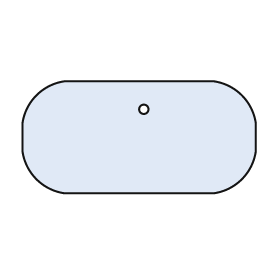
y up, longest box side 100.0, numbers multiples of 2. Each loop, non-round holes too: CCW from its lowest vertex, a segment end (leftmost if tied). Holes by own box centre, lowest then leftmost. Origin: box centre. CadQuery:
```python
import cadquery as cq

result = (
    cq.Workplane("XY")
    .moveTo(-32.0, -24.0)
    .lineTo(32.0, -24.0)
    .threePointArc((44.0, -18.0), (50.0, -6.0))
    .lineTo(50.0, 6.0)
    .threePointArc((44.0, 18.0), (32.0, 24.0))
    .lineTo(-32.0, 24.0)
    .threePointArc((-44.0, 18.0), (-50.0, 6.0))
    .lineTo(-50.0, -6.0)
    .threePointArc((-44.0, -18.0), (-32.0, -24.0))
    .close()
    .moveTo(2.0, 12.0)
    .circle(2.0)
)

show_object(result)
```